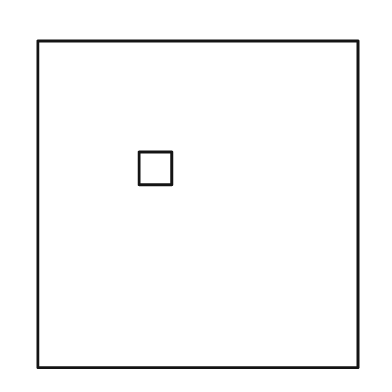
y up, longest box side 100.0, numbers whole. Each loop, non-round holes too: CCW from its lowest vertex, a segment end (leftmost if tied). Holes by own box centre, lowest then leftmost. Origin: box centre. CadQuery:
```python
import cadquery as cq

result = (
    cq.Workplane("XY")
    .moveTo(-49.0, -50.0)
    .lineTo(49.0, -50.0)
    .lineTo(49.0, 50.0)
    .lineTo(-49.0, 50.0)
    .close()
    .moveTo(-18.0, 6.0)
    .lineTo(-8.0, 6.0)
    .lineTo(-8.0, 16.0)
    .lineTo(-18.0, 16.0)
    .close()
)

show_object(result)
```